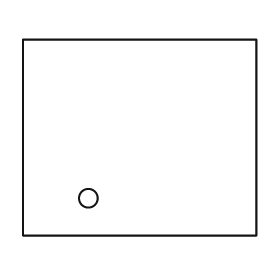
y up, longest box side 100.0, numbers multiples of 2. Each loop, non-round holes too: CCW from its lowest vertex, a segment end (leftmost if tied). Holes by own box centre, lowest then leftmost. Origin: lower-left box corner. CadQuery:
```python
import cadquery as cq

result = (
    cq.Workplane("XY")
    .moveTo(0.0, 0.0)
    .lineTo(100.0, 0.0)
    .lineTo(100.0, 84.0)
    .lineTo(0.0, 84.0)
    .close()
    .moveTo(28.0, 16.0)
    .circle(4.0)
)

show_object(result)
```